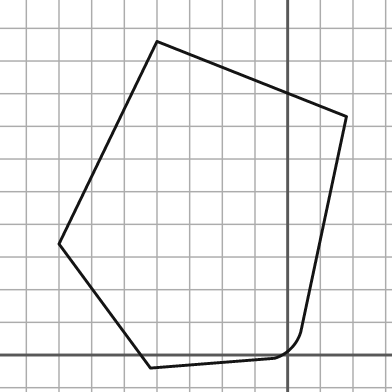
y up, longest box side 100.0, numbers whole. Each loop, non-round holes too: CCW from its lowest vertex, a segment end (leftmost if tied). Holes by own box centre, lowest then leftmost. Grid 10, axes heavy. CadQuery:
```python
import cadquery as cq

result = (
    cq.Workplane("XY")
    .moveTo(-42.0, -4.0)
    .lineTo(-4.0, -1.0)
    .threePointArc((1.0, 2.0), (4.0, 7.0))
    .lineTo(18.0, 73.0)
    .lineTo(-40.0, 96.0)
    .lineTo(-70.0, 34.0)
    .close()
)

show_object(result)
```